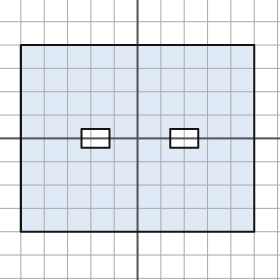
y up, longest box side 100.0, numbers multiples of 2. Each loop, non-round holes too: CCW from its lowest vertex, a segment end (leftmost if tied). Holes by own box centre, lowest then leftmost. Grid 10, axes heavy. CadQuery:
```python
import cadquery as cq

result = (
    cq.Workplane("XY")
    .moveTo(-50.0, -40.0)
    .lineTo(50.0, -40.0)
    .lineTo(50.0, 40.0)
    .lineTo(-50.0, 40.0)
    .close()
    .moveTo(-24.0, -4.0)
    .lineTo(-12.0, -4.0)
    .lineTo(-12.0, 4.0)
    .lineTo(-24.0, 4.0)
    .close()
    .moveTo(14.0, -4.0)
    .lineTo(26.0, -4.0)
    .lineTo(26.0, 4.0)
    .lineTo(14.0, 4.0)
    .close()
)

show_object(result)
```